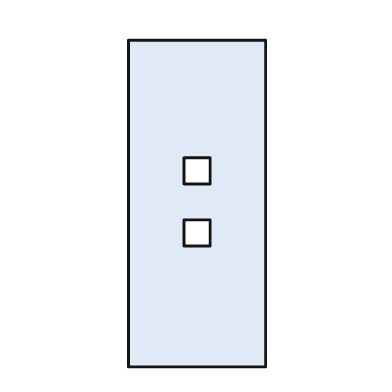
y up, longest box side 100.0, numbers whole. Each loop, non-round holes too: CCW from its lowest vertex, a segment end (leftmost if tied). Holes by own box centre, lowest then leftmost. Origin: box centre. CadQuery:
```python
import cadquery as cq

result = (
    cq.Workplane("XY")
    .moveTo(-21.0, -50.0)
    .lineTo(21.0, -50.0)
    .lineTo(21.0, 50.0)
    .lineTo(-21.0, 50.0)
    .close()
    .moveTo(-4.0, -13.0)
    .lineTo(4.0, -13.0)
    .lineTo(4.0, -5.0)
    .lineTo(-4.0, -5.0)
    .close()
    .moveTo(-4.0, 6.0)
    .lineTo(4.0, 6.0)
    .lineTo(4.0, 14.0)
    .lineTo(-4.0, 14.0)
    .close()
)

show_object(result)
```